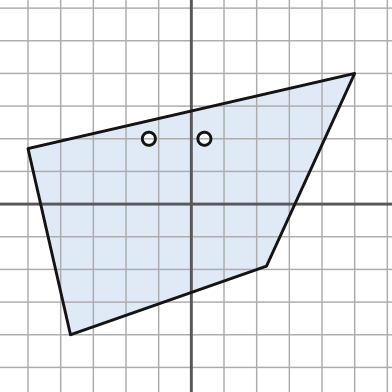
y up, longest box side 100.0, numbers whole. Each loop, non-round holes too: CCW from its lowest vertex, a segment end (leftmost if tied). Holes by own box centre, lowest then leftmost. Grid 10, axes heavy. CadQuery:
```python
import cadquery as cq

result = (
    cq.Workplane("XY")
    .moveTo(-37.0, -40.0)
    .lineTo(23.0, -19.0)
    .lineTo(50.0, 40.0)
    .lineTo(-50.0, 17.0)
    .close()
    .moveTo(-13.0, 20.0)
    .circle(2.0)
    .moveTo(4.0, 20.0)
    .circle(2.0)
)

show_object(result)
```